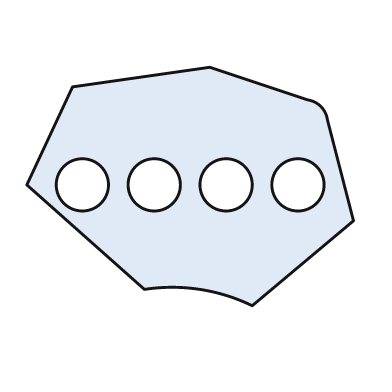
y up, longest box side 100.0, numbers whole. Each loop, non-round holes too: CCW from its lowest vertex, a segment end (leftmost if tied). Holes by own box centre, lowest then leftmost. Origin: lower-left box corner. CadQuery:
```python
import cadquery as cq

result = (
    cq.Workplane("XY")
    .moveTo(69.0, 0.0)
    .lineTo(100.0, 26.0)
    .lineTo(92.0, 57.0)
    .threePointArc((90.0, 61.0), (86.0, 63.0))
    .lineTo(56.0, 73.0)
    .lineTo(14.0, 67.0)
    .lineTo(0.0, 37.0)
    .lineTo(36.0, 5.0)
    .threePointArc((53.0, 5.0), (69.0, 0.0))
    .close()
    .moveTo(17.0, 37.0)
    .circle(8.0)
    .moveTo(39.0, 37.0)
    .circle(8.0)
    .moveTo(61.0, 37.0)
    .circle(8.0)
    .moveTo(83.0, 37.0)
    .circle(8.0)
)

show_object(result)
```